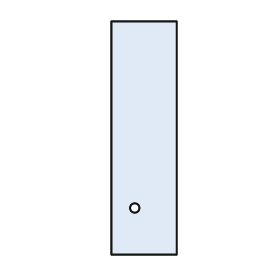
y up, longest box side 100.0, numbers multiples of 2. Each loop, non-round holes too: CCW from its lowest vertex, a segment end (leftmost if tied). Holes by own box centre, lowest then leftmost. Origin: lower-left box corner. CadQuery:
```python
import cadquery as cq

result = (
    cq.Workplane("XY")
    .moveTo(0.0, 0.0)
    .lineTo(28.0, 0.0)
    .lineTo(28.0, 100.0)
    .lineTo(0.0, 100.0)
    .close()
    .moveTo(10.0, 20.0)
    .circle(2.0)
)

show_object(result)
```